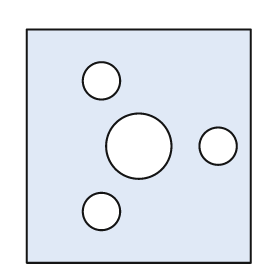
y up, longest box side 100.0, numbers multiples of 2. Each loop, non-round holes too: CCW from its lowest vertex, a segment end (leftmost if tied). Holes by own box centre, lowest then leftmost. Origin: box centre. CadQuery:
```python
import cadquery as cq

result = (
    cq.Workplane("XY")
    .moveTo(-48.0, -50.0)
    .lineTo(48.0, -50.0)
    .lineTo(48.0, 50.0)
    .lineTo(-48.0, 50.0)
    .close()
    .moveTo(-16.0, -28.0)
    .circle(8.0)
    .moveTo(0.0, 0.0)
    .circle(14.0)
    .moveTo(34.0, 0.0)
    .circle(8.0)
    .moveTo(-16.0, 28.0)
    .circle(8.0)
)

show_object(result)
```